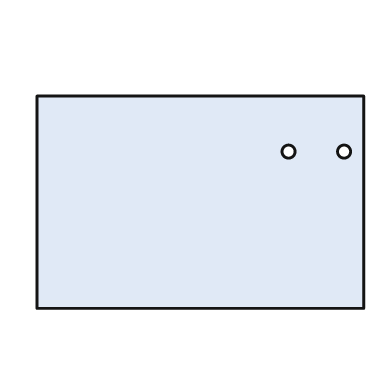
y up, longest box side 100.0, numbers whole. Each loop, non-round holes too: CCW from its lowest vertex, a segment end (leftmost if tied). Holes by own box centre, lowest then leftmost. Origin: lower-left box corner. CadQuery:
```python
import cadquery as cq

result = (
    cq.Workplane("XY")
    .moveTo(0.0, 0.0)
    .lineTo(100.0, 0.0)
    .lineTo(100.0, 65.0)
    .lineTo(0.0, 65.0)
    .close()
    .moveTo(77.0, 48.0)
    .circle(2.0)
    .moveTo(94.0, 48.0)
    .circle(2.0)
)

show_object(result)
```